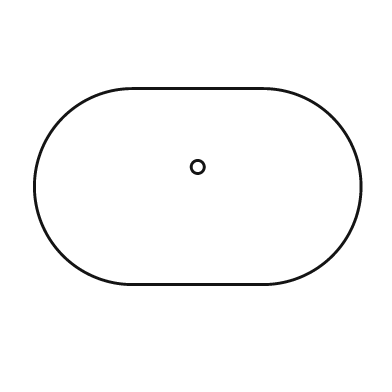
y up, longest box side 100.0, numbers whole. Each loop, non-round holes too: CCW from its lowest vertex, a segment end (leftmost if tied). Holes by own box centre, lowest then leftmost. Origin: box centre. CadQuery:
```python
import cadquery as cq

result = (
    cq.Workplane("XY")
    .moveTo(-20.0, -30.0)
    .lineTo(20.0, -30.0)
    .threePointArc((50.0, 0.0), (20.0, 30.0))
    .lineTo(-20.0, 30.0)
    .threePointArc((-50.0, 0.0), (-20.0, -30.0))
    .close()
    .moveTo(0.0, 6.0)
    .circle(2.0)
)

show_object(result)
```